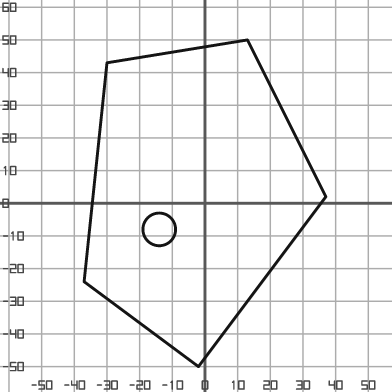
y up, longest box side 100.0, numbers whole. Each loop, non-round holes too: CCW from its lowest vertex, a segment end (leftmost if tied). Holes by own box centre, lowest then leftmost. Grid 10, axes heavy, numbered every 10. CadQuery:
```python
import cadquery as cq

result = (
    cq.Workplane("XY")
    .moveTo(-2.0, -50.0)
    .lineTo(37.0, 2.0)
    .lineTo(13.0, 50.0)
    .lineTo(-30.0, 43.0)
    .lineTo(-37.0, -24.0)
    .close()
    .moveTo(-14.0, -8.0)
    .circle(5.0)
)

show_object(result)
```